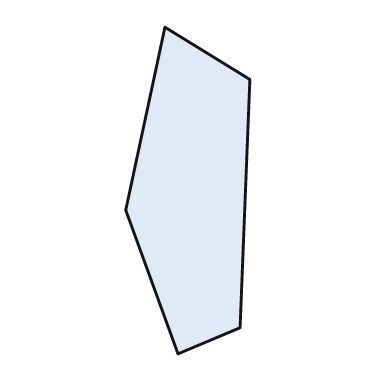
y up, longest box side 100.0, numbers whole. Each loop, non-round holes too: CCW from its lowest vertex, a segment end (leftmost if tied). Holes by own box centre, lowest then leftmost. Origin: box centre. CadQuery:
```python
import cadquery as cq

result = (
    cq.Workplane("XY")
    .moveTo(-3.0, -50.0)
    .lineTo(16.0, -42.0)
    .lineTo(19.0, 34.0)
    .lineTo(-7.0, 50.0)
    .lineTo(-19.0, -6.0)
    .close()
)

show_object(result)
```